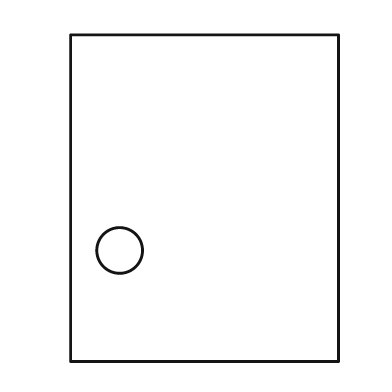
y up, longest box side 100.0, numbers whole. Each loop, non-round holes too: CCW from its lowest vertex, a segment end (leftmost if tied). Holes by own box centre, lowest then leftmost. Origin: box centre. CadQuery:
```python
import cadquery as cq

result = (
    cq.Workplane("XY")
    .moveTo(-41.0, -50.0)
    .lineTo(41.0, -50.0)
    .lineTo(41.0, 50.0)
    .lineTo(-41.0, 50.0)
    .close()
    .moveTo(-26.0, -16.0)
    .circle(7.0)
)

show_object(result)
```